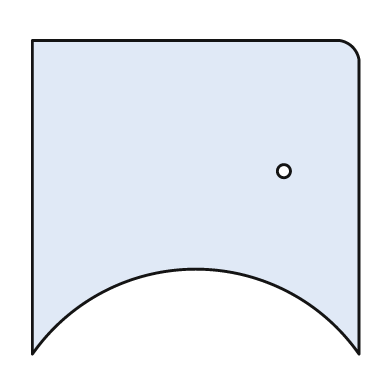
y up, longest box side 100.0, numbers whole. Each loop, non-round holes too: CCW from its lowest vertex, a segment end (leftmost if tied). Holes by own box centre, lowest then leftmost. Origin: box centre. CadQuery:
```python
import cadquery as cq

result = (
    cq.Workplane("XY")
    .moveTo(-50.0, -48.0)
    .threePointArc((0.0, -22.0), (50.0, -48.0))
    .lineTo(50.0, 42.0)
    .threePointArc((48.0, 46.0), (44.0, 48.0))
    .lineTo(-50.0, 48.0)
    .close()
    .moveTo(27.0, 8.0)
    .circle(2.0)
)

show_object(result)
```